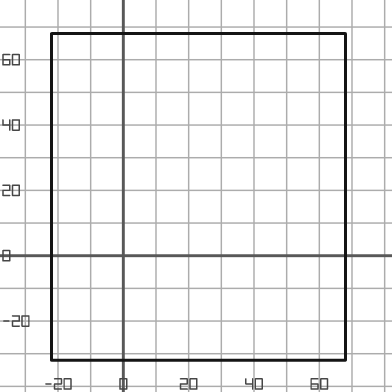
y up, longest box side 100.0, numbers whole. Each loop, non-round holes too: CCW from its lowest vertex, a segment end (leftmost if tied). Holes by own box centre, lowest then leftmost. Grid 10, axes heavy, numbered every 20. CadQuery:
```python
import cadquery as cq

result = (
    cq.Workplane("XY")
    .moveTo(-22.0, -32.0)
    .lineTo(68.0, -32.0)
    .lineTo(68.0, 68.0)
    .lineTo(-22.0, 68.0)
    .close()
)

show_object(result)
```